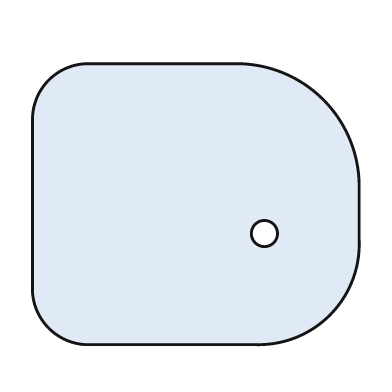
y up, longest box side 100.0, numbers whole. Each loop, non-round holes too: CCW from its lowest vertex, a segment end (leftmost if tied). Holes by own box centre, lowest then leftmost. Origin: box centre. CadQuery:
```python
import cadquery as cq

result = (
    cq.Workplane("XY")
    .moveTo(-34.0, -43.0)
    .lineTo(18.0, -43.0)
    .threePointArc((41.0, -34.0), (50.0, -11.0))
    .lineTo(50.0, 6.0)
    .threePointArc((39.0, 32.0), (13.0, 43.0))
    .lineTo(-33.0, 43.0)
    .threePointArc((-45.0, 38.0), (-50.0, 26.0))
    .lineTo(-50.0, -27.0)
    .threePointArc((-45.0, -38.0), (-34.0, -43.0))
    .close()
    .moveTo(21.0, -9.0)
    .circle(4.0)
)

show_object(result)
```